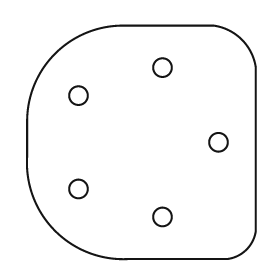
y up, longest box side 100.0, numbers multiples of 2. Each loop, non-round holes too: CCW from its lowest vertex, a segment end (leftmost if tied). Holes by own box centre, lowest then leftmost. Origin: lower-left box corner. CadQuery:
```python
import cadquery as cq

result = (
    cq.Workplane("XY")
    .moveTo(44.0, 0.0)
    .lineTo(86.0, 0.0)
    .threePointArc((94.0, 4.0), (98.0, 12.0))
    .lineTo(98.0, 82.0)
    .threePointArc((92.0, 94.0), (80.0, 100.0))
    .lineTo(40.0, 100.0)
    .threePointArc((12.0, 88.0), (0.0, 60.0))
    .lineTo(0.0, 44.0)
    .threePointArc((12.0, 12.0), (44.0, 0.0))
    .close()
    .moveTo(58.0, 18.0)
    .circle(4.0)
    .moveTo(22.0, 30.0)
    .circle(4.0)
    .moveTo(82.0, 50.0)
    .circle(4.0)
    .moveTo(22.0, 70.0)
    .circle(4.0)
    .moveTo(58.0, 82.0)
    .circle(4.0)
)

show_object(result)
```